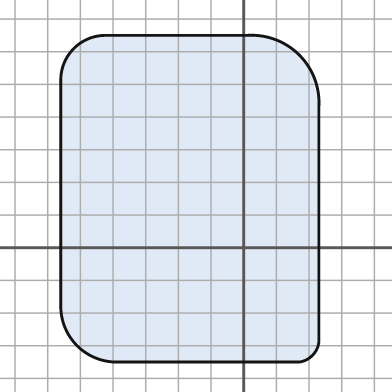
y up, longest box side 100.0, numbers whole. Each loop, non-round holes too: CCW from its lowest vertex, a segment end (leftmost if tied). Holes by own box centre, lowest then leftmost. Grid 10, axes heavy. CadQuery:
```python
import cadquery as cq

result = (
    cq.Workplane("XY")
    .moveTo(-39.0, -35.0)
    .lineTo(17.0, -35.0)
    .threePointArc((21.0, -33.0), (23.0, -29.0))
    .lineTo(23.0, 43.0)
    .threePointArc((17.0, 59.0), (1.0, 65.0))
    .lineTo(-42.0, 65.0)
    .threePointArc((-52.0, 61.0), (-56.0, 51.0))
    .lineTo(-56.0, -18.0)
    .threePointArc((-51.0, -30.0), (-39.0, -35.0))
    .close()
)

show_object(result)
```